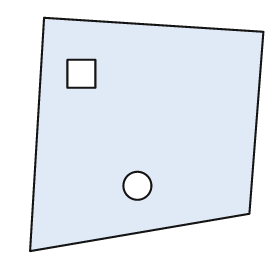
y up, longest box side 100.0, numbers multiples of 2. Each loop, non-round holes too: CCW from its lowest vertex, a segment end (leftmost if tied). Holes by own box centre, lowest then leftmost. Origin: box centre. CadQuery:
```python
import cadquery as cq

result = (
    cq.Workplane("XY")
    .moveTo(-50.0, -50.0)
    .lineTo(44.0, -34.0)
    .lineTo(50.0, 44.0)
    .lineTo(-44.0, 50.0)
    .close()
    .moveTo(-4.0, -22.0)
    .circle(6.0)
    .moveTo(-34.0, 20.0)
    .lineTo(-22.0, 20.0)
    .lineTo(-22.0, 32.0)
    .lineTo(-34.0, 32.0)
    .close()
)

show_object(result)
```